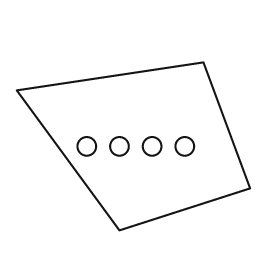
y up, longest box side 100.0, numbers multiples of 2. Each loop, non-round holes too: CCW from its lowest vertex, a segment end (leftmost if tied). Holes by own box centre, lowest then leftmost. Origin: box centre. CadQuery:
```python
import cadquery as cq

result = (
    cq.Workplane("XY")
    .moveTo(-6.0, -36.0)
    .lineTo(50.0, -18.0)
    .lineTo(30.0, 36.0)
    .lineTo(-50.0, 24.0)
    .close()
    .moveTo(-20.0, 0.0)
    .circle(4.0)
    .moveTo(-6.0, 0.0)
    .circle(4.0)
    .moveTo(8.0, 0.0)
    .circle(4.0)
    .moveTo(22.0, 0.0)
    .circle(4.0)
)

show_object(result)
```